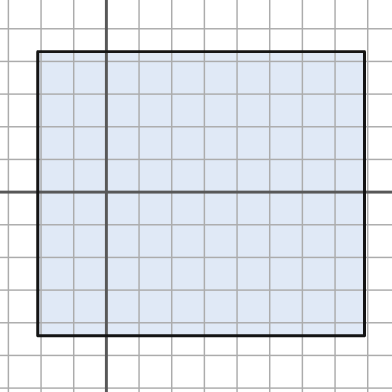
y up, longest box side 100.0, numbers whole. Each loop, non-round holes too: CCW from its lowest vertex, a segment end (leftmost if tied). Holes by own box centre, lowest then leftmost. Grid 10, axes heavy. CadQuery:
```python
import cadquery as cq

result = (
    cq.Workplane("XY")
    .moveTo(-21.0, -44.0)
    .lineTo(79.0, -44.0)
    .lineTo(79.0, 43.0)
    .lineTo(-21.0, 43.0)
    .close()
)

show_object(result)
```